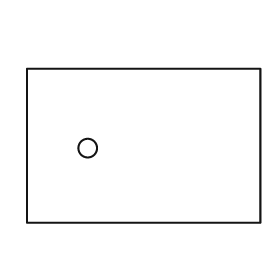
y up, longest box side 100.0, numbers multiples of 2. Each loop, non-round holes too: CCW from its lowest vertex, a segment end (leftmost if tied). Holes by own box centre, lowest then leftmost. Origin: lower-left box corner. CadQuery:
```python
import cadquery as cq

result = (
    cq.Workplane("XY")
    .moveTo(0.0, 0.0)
    .lineTo(100.0, 0.0)
    .lineTo(100.0, 66.0)
    .lineTo(0.0, 66.0)
    .close()
    .moveTo(26.0, 32.0)
    .circle(4.0)
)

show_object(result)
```